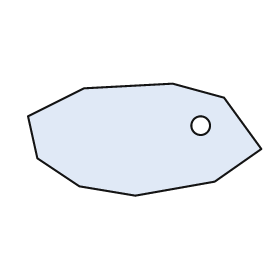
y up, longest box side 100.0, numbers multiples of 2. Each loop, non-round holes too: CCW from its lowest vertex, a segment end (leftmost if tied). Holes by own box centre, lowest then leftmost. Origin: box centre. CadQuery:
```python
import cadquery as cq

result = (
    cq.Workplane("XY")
    .moveTo(-4.0, -24.0)
    .lineTo(30.0, -18.0)
    .lineTo(50.0, -4.0)
    .lineTo(34.0, 18.0)
    .lineTo(12.0, 24.0)
    .lineTo(-26.0, 22.0)
    .lineTo(-50.0, 10.0)
    .lineTo(-46.0, -8.0)
    .lineTo(-28.0, -20.0)
    .close()
    .moveTo(24.0, 6.0)
    .circle(4.0)
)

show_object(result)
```